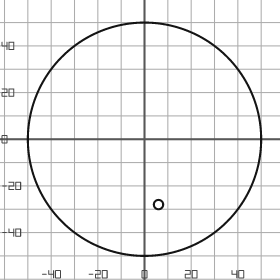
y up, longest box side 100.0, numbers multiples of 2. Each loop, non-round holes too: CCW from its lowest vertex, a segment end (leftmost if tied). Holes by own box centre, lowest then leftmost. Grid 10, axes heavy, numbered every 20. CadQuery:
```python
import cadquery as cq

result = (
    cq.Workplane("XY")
    .moveTo(0.0, 0.0)
    .circle(50.0)
    .moveTo(6.0, -28.0)
    .circle(2.0)
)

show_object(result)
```